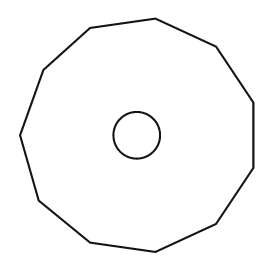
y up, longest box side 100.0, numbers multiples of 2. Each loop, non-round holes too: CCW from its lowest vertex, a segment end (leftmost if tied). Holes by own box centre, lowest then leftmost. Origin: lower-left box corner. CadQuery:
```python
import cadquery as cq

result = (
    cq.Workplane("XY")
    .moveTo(58.0, 0.0)
    .lineTo(84.0, 12.0)
    .lineTo(100.0, 36.0)
    .lineTo(100.0, 64.0)
    .lineTo(84.0, 88.0)
    .lineTo(58.0, 100.0)
    .lineTo(30.0, 96.0)
    .lineTo(10.0, 78.0)
    .lineTo(0.0, 50.0)
    .lineTo(8.0, 22.0)
    .lineTo(30.0, 4.0)
    .close()
    .moveTo(50.0, 50.0)
    .circle(10.0)
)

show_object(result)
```